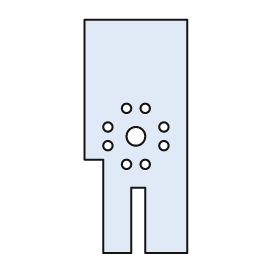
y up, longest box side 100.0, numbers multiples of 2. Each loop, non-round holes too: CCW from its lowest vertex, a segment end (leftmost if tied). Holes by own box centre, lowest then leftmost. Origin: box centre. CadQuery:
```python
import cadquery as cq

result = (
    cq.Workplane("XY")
    .moveTo(-14.0, -50.0)
    .lineTo(-2.0, -50.0)
    .lineTo(-2.0, -22.0)
    .lineTo(4.0, -22.0)
    .lineTo(4.0, -50.0)
    .lineTo(22.0, -50.0)
    .lineTo(22.0, 50.0)
    .lineTo(-22.0, 50.0)
    .lineTo(-22.0, -10.0)
    .lineTo(-14.0, -10.0)
    .close()
    .moveTo(-4.0, -12.0)
    .circle(2.0)
    .moveTo(4.0, -12.0)
    .circle(2.0)
    .moveTo(-12.0, -4.0)
    .circle(2.0)
    .moveTo(12.0, -4.0)
    .circle(2.0)
    .moveTo(0.0, 0.0)
    .circle(4.0)
    .moveTo(-12.0, 4.0)
    .circle(2.0)
    .moveTo(12.0, 4.0)
    .circle(2.0)
    .moveTo(-4.0, 12.0)
    .circle(2.0)
    .moveTo(4.0, 12.0)
    .circle(2.0)
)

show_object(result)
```